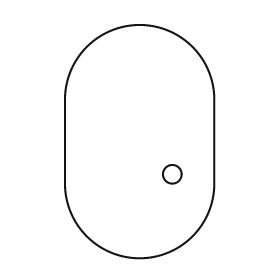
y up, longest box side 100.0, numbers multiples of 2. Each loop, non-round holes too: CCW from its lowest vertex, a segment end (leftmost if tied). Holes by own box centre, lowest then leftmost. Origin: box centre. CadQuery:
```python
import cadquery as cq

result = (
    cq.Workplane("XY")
    .moveTo(-32.0, -18.0)
    .threePointArc((0.0, -50.0), (32.0, -18.0))
    .lineTo(32.0, 18.0)
    .threePointArc((0.0, 50.0), (-32.0, 18.0))
    .close()
    .moveTo(14.0, -14.0)
    .circle(4.0)
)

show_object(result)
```